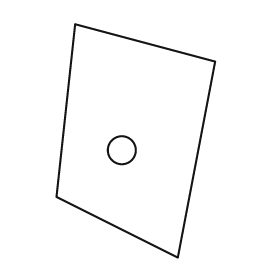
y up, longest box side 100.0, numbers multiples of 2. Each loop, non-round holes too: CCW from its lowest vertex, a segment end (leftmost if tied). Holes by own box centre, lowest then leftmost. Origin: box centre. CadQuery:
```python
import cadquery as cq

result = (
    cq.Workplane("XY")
    .moveTo(18.0, -50.0)
    .lineTo(34.0, 34.0)
    .lineTo(-26.0, 50.0)
    .lineTo(-34.0, -24.0)
    .close()
    .moveTo(-6.0, -4.0)
    .circle(6.0)
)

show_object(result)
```